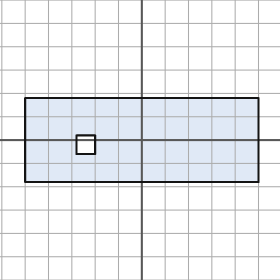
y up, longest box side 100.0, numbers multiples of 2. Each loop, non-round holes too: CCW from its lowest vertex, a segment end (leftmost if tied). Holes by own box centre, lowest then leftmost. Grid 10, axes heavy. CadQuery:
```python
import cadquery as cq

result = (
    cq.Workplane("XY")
    .moveTo(-50.0, -18.0)
    .lineTo(50.0, -18.0)
    .lineTo(50.0, 18.0)
    .lineTo(-50.0, 18.0)
    .close()
    .moveTo(-28.0, -6.0)
    .lineTo(-20.0, -6.0)
    .lineTo(-20.0, 2.0)
    .lineTo(-28.0, 2.0)
    .close()
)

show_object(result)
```